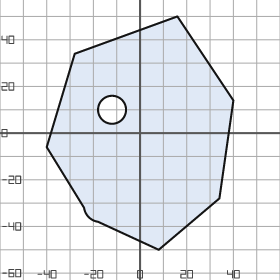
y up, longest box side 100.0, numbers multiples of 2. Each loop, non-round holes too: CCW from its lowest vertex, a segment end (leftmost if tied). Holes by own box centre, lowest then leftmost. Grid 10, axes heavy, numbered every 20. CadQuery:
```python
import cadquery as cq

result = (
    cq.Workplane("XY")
    .moveTo(8.0, -50.0)
    .lineTo(34.0, -28.0)
    .lineTo(40.0, 14.0)
    .lineTo(16.0, 50.0)
    .lineTo(-28.0, 34.0)
    .lineTo(-40.0, -6.0)
    .lineTo(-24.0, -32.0)
    .threePointArc((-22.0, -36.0), (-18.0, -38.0))
    .close()
    .moveTo(-12.0, 10.0)
    .circle(6.0)
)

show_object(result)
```